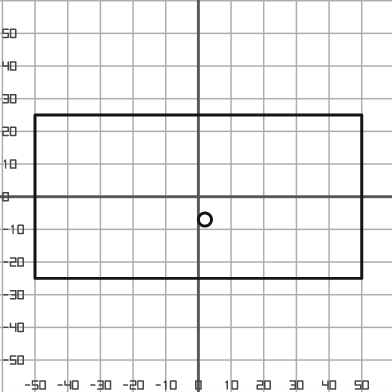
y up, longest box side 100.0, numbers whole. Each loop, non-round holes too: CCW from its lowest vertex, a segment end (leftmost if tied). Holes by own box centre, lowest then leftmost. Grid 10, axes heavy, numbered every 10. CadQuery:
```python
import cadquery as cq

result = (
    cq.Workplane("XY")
    .moveTo(-50.0, -25.0)
    .lineTo(50.0, -25.0)
    .lineTo(50.0, 25.0)
    .lineTo(-50.0, 25.0)
    .close()
    .moveTo(2.0, -7.0)
    .circle(2.0)
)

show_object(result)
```